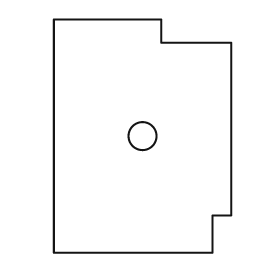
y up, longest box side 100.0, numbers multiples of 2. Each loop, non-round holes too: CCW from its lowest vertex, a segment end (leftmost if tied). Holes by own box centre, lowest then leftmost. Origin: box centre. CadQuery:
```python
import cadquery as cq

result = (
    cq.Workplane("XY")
    .moveTo(-38.0, -50.0)
    .lineTo(30.0, -50.0)
    .lineTo(30.0, -34.0)
    .lineTo(38.0, -34.0)
    .lineTo(38.0, 40.0)
    .lineTo(8.0, 40.0)
    .lineTo(8.0, 50.0)
    .lineTo(-38.0, 50.0)
    .close()
    .moveTo(0.0, 0.0)
    .circle(6.0)
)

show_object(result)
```